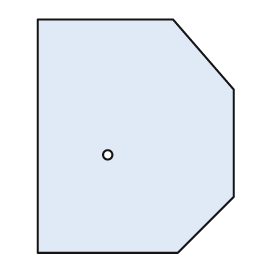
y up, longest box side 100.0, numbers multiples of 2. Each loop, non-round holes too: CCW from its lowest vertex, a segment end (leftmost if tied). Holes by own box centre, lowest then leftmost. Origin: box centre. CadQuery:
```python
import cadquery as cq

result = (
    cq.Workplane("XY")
    .moveTo(-42.0, -50.0)
    .lineTo(18.0, -50.0)
    .lineTo(42.0, -26.0)
    .lineTo(42.0, 20.0)
    .lineTo(16.0, 50.0)
    .lineTo(-42.0, 50.0)
    .close()
    .moveTo(-12.0, -8.0)
    .circle(2.0)
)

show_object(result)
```